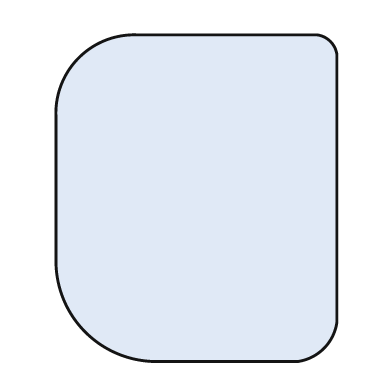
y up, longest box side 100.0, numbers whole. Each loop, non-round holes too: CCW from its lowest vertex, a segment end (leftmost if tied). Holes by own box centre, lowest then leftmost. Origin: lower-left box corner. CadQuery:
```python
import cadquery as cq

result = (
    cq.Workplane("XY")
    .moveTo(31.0, 0.0)
    .lineTo(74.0, 0.0)
    .threePointArc((82.0, 4.0), (86.0, 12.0))
    .lineTo(86.0, 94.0)
    .threePointArc((84.0, 98.0), (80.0, 100.0))
    .lineTo(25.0, 100.0)
    .threePointArc((7.0, 93.0), (0.0, 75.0))
    .lineTo(0.0, 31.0)
    .threePointArc((9.0, 9.0), (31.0, 0.0))
    .close()
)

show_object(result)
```